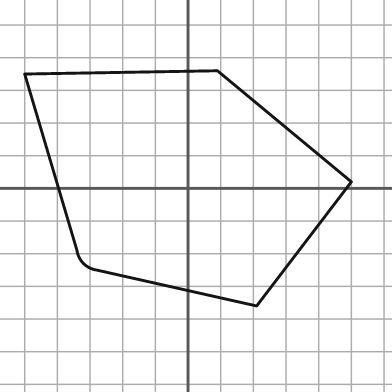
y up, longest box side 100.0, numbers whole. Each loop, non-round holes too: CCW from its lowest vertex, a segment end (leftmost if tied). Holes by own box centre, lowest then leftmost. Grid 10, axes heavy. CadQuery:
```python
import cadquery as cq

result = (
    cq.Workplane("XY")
    .moveTo(21.0, -36.0)
    .lineTo(50.0, 2.0)
    .lineTo(9.0, 36.0)
    .lineTo(-50.0, 35.0)
    .lineTo(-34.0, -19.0)
    .threePointArc((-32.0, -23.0), (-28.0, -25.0))
    .close()
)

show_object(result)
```